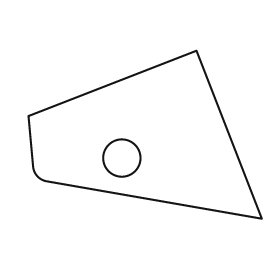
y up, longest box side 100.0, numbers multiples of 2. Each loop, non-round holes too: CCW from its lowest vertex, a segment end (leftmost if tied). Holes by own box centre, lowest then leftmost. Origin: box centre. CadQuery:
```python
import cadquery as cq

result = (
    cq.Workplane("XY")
    .moveTo(50.0, -36.0)
    .lineTo(22.0, 36.0)
    .lineTo(-50.0, 8.0)
    .lineTo(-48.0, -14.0)
    .threePointArc((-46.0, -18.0), (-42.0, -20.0))
    .close()
    .moveTo(-10.0, -10.0)
    .circle(8.0)
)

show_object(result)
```